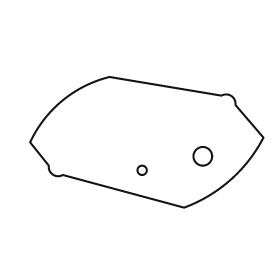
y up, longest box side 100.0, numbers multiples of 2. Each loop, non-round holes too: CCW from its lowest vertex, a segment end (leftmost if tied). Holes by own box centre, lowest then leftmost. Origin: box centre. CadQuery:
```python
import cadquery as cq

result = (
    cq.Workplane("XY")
    .moveTo(16.0, -28.0)
    .threePointArc((36.0, -16.0), (50.0, 2.0))
    .lineTo(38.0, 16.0)
    .threePointArc((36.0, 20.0), (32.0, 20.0))
    .lineTo(-16.0, 28.0)
    .threePointArc((-36.0, 18.0), (-50.0, 0.0))
    .lineTo(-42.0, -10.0)
    .threePointArc((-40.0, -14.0), (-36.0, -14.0))
    .close()
    .moveTo(-2.0, -12.0)
    .circle(2.0)
    .moveTo(24.0, -6.0)
    .circle(4.0)
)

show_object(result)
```